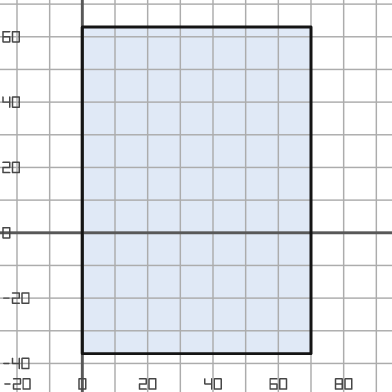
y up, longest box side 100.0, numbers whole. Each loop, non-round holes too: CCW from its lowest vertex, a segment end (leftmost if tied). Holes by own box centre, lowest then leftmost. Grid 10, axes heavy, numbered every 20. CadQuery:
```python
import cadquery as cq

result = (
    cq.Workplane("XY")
    .moveTo(0.0, -37.0)
    .lineTo(70.0, -37.0)
    .lineTo(70.0, 63.0)
    .lineTo(0.0, 63.0)
    .close()
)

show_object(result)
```